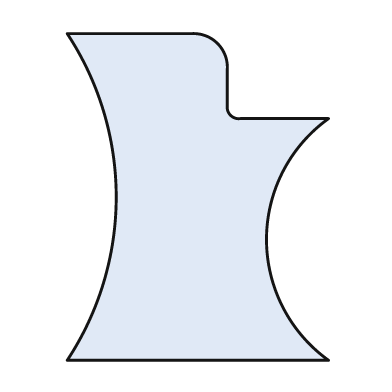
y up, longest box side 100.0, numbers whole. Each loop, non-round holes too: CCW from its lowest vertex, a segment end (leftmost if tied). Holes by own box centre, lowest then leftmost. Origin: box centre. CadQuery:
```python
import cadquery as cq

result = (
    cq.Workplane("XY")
    .moveTo(-40.0, -50.0)
    .lineTo(40.0, -50.0)
    .threePointArc((21.0, -13.0), (40.0, 24.0))
    .lineTo(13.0, 24.0)
    .threePointArc((10.0, 25.0), (9.0, 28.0))
    .lineTo(9.0, 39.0)
    .threePointArc((6.0, 47.0), (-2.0, 50.0))
    .lineTo(-40.0, 50.0)
    .threePointArc((-25.0, 0.0), (-40.0, -50.0))
    .close()
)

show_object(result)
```